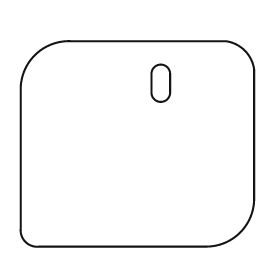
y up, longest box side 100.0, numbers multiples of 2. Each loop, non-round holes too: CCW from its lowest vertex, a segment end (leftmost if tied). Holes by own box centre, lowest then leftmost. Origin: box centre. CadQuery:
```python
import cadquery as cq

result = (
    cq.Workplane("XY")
    .moveTo(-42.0, -44.0)
    .lineTo(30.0, -44.0)
    .threePointArc((44.0, -38.0), (50.0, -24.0))
    .lineTo(50.0, 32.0)
    .threePointArc((46.0, 40.0), (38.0, 44.0))
    .lineTo(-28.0, 44.0)
    .threePointArc((-44.0, 38.0), (-50.0, 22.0))
    .lineTo(-50.0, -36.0)
    .threePointArc((-48.0, -42.0), (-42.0, -44.0))
    .close()
    .moveTo(6.0, 22.0)
    .threePointArc((10.0, 18.0), (14.0, 22.0))
    .lineTo(14.0, 30.0)
    .threePointArc((10.0, 34.0), (6.0, 30.0))
    .close()
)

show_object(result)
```